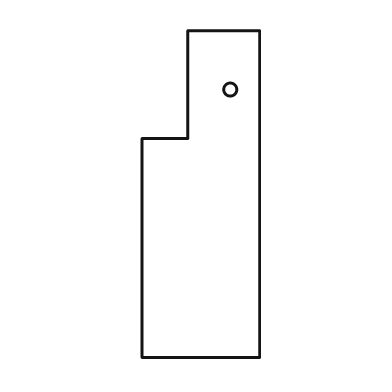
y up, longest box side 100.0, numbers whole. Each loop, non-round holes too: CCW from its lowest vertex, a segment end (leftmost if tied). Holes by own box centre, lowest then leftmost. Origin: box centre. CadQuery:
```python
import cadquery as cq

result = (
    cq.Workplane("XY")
    .moveTo(-18.0, -50.0)
    .lineTo(18.0, -50.0)
    .lineTo(18.0, 50.0)
    .lineTo(-4.0, 50.0)
    .lineTo(-4.0, 17.0)
    .lineTo(-18.0, 17.0)
    .close()
    .moveTo(9.0, 32.0)
    .circle(2.0)
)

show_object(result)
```